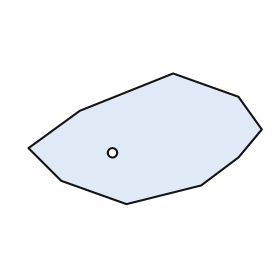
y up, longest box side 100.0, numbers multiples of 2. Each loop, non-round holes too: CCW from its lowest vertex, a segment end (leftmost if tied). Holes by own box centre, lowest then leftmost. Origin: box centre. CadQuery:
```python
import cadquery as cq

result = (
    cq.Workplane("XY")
    .moveTo(-8.0, -28.0)
    .lineTo(24.0, -20.0)
    .lineTo(40.0, -8.0)
    .lineTo(50.0, 4.0)
    .lineTo(40.0, 18.0)
    .lineTo(12.0, 28.0)
    .lineTo(-28.0, 12.0)
    .lineTo(-50.0, -4.0)
    .lineTo(-36.0, -18.0)
    .close()
    .moveTo(-14.0, -6.0)
    .circle(2.0)
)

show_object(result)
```